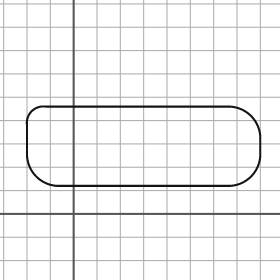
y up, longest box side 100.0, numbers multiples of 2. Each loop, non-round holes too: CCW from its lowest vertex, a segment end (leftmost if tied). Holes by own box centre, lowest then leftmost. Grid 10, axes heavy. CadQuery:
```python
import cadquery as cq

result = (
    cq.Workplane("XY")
    .moveTo(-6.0, 12.0)
    .lineTo(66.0, 12.0)
    .threePointArc((76.0, 16.0), (80.0, 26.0))
    .lineTo(80.0, 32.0)
    .threePointArc((76.0, 42.0), (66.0, 46.0))
    .lineTo(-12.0, 46.0)
    .threePointArc((-18.0, 44.0), (-20.0, 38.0))
    .lineTo(-20.0, 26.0)
    .threePointArc((-16.0, 16.0), (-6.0, 12.0))
    .close()
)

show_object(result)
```